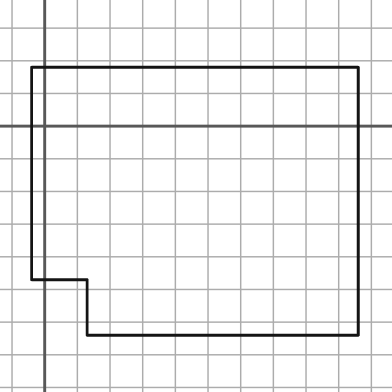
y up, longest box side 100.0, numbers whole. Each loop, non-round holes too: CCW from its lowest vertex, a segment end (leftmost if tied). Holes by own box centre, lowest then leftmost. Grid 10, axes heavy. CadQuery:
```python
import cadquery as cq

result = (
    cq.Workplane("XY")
    .moveTo(13.0, -64.0)
    .lineTo(96.0, -64.0)
    .lineTo(96.0, 18.0)
    .lineTo(-4.0, 18.0)
    .lineTo(-4.0, -47.0)
    .lineTo(13.0, -47.0)
    .close()
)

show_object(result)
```